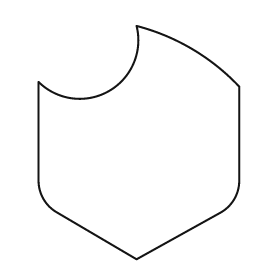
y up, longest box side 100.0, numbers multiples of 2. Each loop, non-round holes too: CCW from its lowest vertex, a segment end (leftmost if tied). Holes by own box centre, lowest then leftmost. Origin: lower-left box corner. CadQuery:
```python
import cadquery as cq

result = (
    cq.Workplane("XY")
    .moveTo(42.0, 0.0)
    .lineTo(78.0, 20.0)
    .threePointArc((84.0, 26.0), (86.0, 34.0))
    .lineTo(86.0, 74.0)
    .threePointArc((66.0, 90.0), (42.0, 100.0))
    .threePointArc((30.0, 72.0), (0.0, 76.0))
    .lineTo(0.0, 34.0)
    .threePointArc((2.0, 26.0), (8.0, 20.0))
    .close()
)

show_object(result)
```